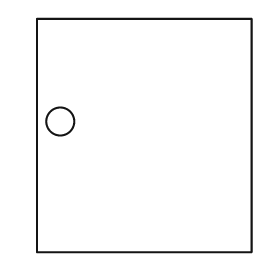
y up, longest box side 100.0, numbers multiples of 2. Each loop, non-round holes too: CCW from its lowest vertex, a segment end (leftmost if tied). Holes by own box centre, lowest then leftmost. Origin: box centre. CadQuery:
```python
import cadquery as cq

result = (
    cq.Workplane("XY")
    .moveTo(-46.0, -50.0)
    .lineTo(46.0, -50.0)
    .lineTo(46.0, 50.0)
    .lineTo(-46.0, 50.0)
    .close()
    .moveTo(-36.0, 6.0)
    .circle(6.0)
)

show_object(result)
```